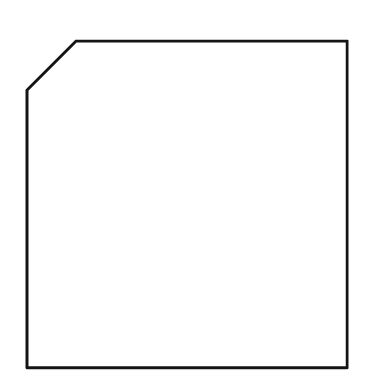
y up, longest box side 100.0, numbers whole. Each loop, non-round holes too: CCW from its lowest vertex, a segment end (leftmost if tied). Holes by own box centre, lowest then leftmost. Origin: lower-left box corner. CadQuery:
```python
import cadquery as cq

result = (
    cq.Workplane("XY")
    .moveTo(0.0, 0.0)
    .lineTo(98.0, 0.0)
    .lineTo(98.0, 100.0)
    .lineTo(15.0, 100.0)
    .lineTo(0.0, 85.0)
    .close()
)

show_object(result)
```